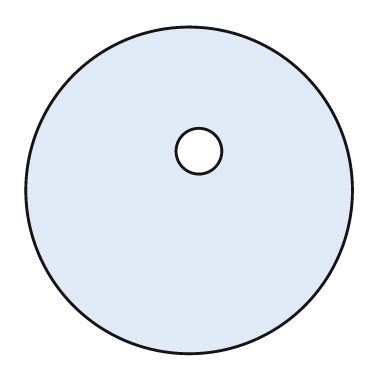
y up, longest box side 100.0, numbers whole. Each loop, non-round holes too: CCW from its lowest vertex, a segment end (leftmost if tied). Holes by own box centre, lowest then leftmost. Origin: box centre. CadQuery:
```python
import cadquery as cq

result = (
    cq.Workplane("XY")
    .moveTo(0.0, 0.0)
    .circle(50.0)
    .moveTo(3.0, 12.0)
    .circle(7.0)
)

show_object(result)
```